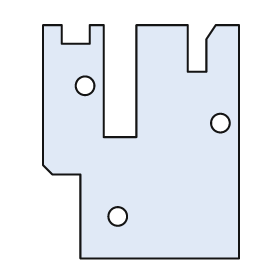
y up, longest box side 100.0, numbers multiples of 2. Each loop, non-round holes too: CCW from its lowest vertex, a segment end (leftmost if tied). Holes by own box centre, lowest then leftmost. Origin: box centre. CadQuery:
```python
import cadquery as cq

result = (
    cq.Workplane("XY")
    .moveTo(-26.0, -50.0)
    .lineTo(42.0, -50.0)
    .lineTo(42.0, 50.0)
    .lineTo(32.0, 50.0)
    .lineTo(28.0, 44.0)
    .lineTo(28.0, 30.0)
    .lineTo(20.0, 30.0)
    .lineTo(20.0, 50.0)
    .lineTo(-2.0, 50.0)
    .lineTo(-2.0, 2.0)
    .lineTo(-16.0, 2.0)
    .lineTo(-16.0, 50.0)
    .lineTo(-22.0, 50.0)
    .lineTo(-22.0, 42.0)
    .lineTo(-34.0, 42.0)
    .lineTo(-34.0, 50.0)
    .lineTo(-42.0, 50.0)
    .lineTo(-42.0, -10.0)
    .lineTo(-38.0, -14.0)
    .lineTo(-26.0, -14.0)
    .close()
    .moveTo(-10.0, -32.0)
    .circle(4.0)
    .moveTo(34.0, 8.0)
    .circle(4.0)
    .moveTo(-24.0, 24.0)
    .circle(4.0)
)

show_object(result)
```